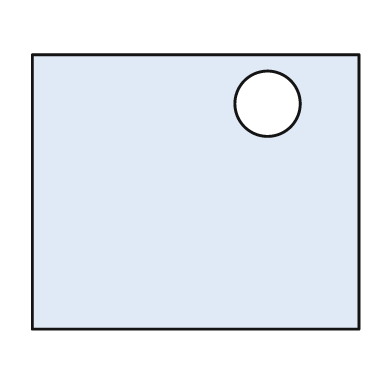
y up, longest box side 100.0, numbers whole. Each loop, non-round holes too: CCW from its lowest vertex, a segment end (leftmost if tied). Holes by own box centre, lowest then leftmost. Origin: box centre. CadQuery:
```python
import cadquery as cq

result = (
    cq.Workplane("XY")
    .moveTo(-50.0, -42.0)
    .lineTo(50.0, -42.0)
    .lineTo(50.0, 42.0)
    .lineTo(-50.0, 42.0)
    .close()
    .moveTo(22.0, 27.0)
    .circle(10.0)
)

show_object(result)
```